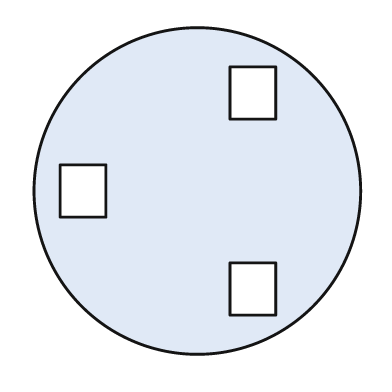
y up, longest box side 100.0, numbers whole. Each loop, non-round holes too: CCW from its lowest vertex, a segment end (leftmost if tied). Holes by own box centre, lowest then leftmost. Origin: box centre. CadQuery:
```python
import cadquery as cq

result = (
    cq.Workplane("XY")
    .moveTo(0.0, 0.0)
    .circle(50.0)
    .moveTo(10.0, -38.0)
    .lineTo(24.0, -38.0)
    .lineTo(24.0, -22.0)
    .lineTo(10.0, -22.0)
    .close()
    .moveTo(-42.0, -8.0)
    .lineTo(-28.0, -8.0)
    .lineTo(-28.0, 8.0)
    .lineTo(-42.0, 8.0)
    .close()
    .moveTo(10.0, 22.0)
    .lineTo(24.0, 22.0)
    .lineTo(24.0, 38.0)
    .lineTo(10.0, 38.0)
    .close()
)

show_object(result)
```